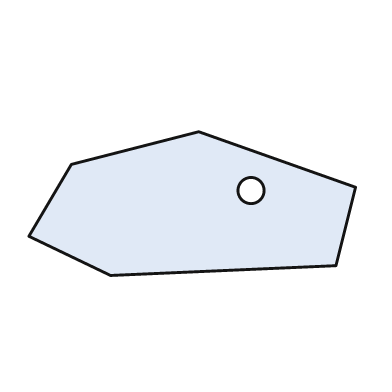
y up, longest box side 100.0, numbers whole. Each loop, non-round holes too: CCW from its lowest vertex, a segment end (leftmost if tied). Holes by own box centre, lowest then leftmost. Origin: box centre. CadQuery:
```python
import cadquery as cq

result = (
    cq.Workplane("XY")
    .moveTo(-25.0, -22.0)
    .lineTo(44.0, -19.0)
    .lineTo(50.0, 5.0)
    .lineTo(2.0, 22.0)
    .lineTo(-37.0, 12.0)
    .lineTo(-50.0, -10.0)
    .close()
    .moveTo(18.0, 4.0)
    .circle(4.0)
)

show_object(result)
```